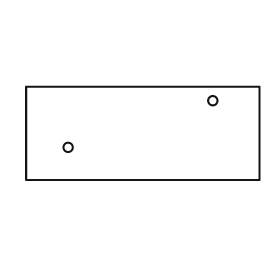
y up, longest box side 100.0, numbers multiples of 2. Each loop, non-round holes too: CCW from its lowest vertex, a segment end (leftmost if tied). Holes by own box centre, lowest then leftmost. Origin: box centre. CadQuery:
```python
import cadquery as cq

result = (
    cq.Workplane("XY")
    .moveTo(-50.0, -20.0)
    .lineTo(50.0, -20.0)
    .lineTo(50.0, 20.0)
    .lineTo(-50.0, 20.0)
    .close()
    .moveTo(-32.0, -6.0)
    .circle(2.0)
    .moveTo(30.0, 14.0)
    .circle(2.0)
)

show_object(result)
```